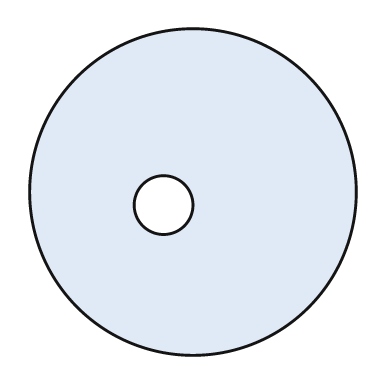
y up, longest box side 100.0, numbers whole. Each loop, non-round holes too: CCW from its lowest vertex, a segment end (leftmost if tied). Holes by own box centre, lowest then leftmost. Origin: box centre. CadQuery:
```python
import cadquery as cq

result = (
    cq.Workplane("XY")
    .moveTo(0.0, 0.0)
    .circle(50.0)
    .moveTo(-9.0, -4.0)
    .circle(9.0)
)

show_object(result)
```